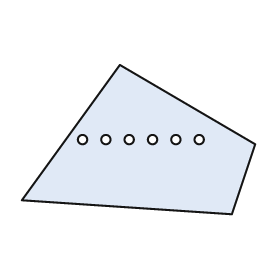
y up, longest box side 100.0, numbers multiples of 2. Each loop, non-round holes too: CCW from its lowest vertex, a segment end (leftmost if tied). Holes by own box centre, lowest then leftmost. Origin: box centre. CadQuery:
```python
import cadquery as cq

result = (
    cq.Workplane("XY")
    .moveTo(40.0, -32.0)
    .lineTo(50.0, -2.0)
    .lineTo(-8.0, 32.0)
    .lineTo(-50.0, -26.0)
    .close()
    .moveTo(-24.0, 0.0)
    .circle(2.0)
    .moveTo(-14.0, 0.0)
    .circle(2.0)
    .moveTo(-4.0, 0.0)
    .circle(2.0)
    .moveTo(6.0, 0.0)
    .circle(2.0)
    .moveTo(16.0, 0.0)
    .circle(2.0)
    .moveTo(26.0, 0.0)
    .circle(2.0)
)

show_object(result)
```